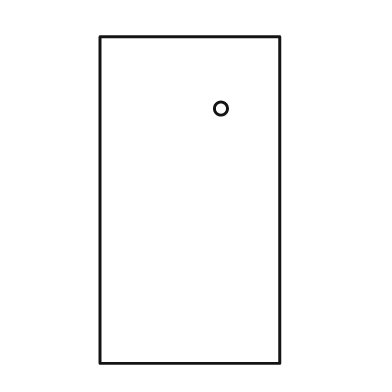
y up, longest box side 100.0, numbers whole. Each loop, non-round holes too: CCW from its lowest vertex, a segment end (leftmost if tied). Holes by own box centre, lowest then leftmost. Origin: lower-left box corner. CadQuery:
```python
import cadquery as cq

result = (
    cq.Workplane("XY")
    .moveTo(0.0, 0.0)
    .lineTo(55.0, 0.0)
    .lineTo(55.0, 100.0)
    .lineTo(0.0, 100.0)
    .close()
    .moveTo(37.0, 78.0)
    .circle(2.0)
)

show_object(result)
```